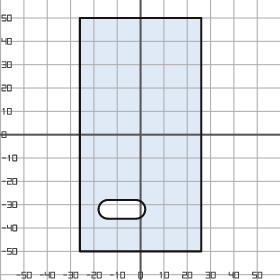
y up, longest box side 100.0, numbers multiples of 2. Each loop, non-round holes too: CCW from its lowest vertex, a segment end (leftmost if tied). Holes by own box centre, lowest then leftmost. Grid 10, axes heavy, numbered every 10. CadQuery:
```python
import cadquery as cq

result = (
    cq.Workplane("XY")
    .moveTo(-26.0, -50.0)
    .lineTo(26.0, -50.0)
    .lineTo(26.0, 50.0)
    .lineTo(-26.0, 50.0)
    .close()
    .moveTo(-14.0, -36.0)
    .lineTo(-2.0, -36.0)
    .threePointArc((2.0, -32.0), (-2.0, -28.0))
    .lineTo(-14.0, -28.0)
    .threePointArc((-18.0, -32.0), (-14.0, -36.0))
    .close()
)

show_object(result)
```